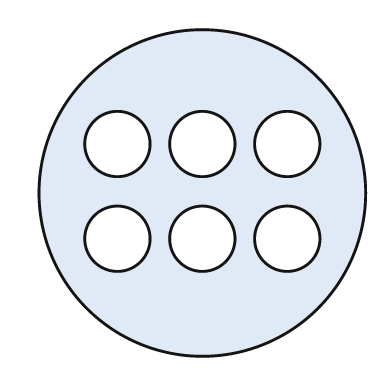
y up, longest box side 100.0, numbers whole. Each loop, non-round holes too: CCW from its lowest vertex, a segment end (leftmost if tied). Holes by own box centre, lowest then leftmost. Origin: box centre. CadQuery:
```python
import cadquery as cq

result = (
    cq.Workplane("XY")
    .moveTo(0.0, 0.0)
    .circle(50.0)
    .moveTo(-26.0, -14.0)
    .circle(10.0)
    .moveTo(0.0, -14.0)
    .circle(10.0)
    .moveTo(26.0, -14.0)
    .circle(10.0)
    .moveTo(-26.0, 15.0)
    .circle(10.0)
    .moveTo(0.0, 15.0)
    .circle(10.0)
    .moveTo(26.0, 15.0)
    .circle(10.0)
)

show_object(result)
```